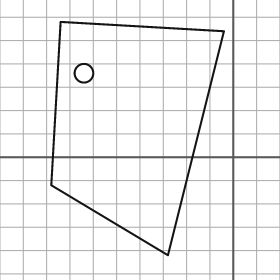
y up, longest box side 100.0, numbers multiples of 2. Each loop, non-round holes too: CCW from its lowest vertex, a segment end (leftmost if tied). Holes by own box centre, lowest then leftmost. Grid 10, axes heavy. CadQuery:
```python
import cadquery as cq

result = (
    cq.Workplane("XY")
    .moveTo(-28.0, -42.0)
    .lineTo(-4.0, 54.0)
    .lineTo(-74.0, 58.0)
    .lineTo(-78.0, -12.0)
    .close()
    .moveTo(-64.0, 36.0)
    .circle(4.0)
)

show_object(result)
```